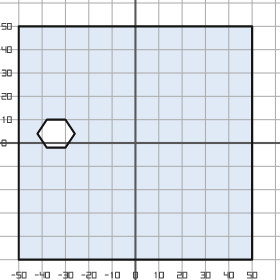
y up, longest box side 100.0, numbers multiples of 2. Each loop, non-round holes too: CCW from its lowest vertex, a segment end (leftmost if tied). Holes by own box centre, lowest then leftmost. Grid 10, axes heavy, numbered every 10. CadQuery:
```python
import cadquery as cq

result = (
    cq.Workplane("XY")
    .moveTo(-50.0, -50.0)
    .lineTo(50.0, -50.0)
    .lineTo(50.0, 50.0)
    .lineTo(-50.0, 50.0)
    .close()
    .moveTo(-38.0, -2.0)
    .lineTo(-30.0, -2.0)
    .lineTo(-26.0, 4.0)
    .lineTo(-30.0, 10.0)
    .lineTo(-38.0, 10.0)
    .lineTo(-42.0, 4.0)
    .close()
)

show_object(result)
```